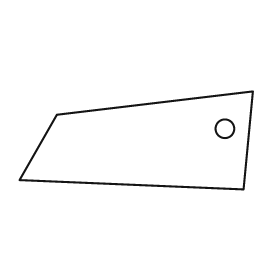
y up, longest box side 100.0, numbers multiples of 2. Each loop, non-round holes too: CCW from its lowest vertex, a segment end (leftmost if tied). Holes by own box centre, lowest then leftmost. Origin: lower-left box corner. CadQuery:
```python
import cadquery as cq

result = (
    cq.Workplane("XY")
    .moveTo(96.0, 0.0)
    .lineTo(100.0, 42.0)
    .lineTo(16.0, 32.0)
    .lineTo(0.0, 4.0)
    .close()
    .moveTo(88.0, 26.0)
    .circle(4.0)
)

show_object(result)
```